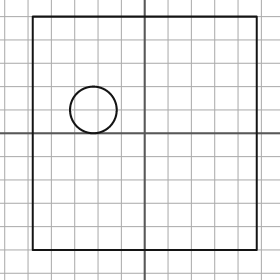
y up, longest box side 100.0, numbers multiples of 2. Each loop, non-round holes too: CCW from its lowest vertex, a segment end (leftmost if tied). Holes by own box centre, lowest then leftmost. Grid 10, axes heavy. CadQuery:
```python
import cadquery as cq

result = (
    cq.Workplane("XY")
    .moveTo(-48.0, -50.0)
    .lineTo(48.0, -50.0)
    .lineTo(48.0, 50.0)
    .lineTo(-48.0, 50.0)
    .close()
    .moveTo(-22.0, 10.0)
    .circle(10.0)
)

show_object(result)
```